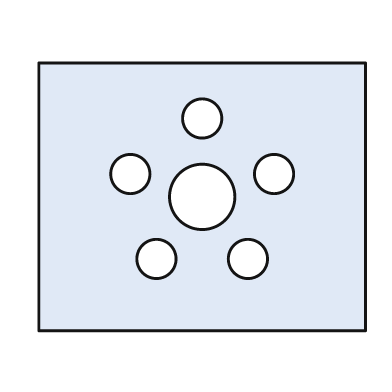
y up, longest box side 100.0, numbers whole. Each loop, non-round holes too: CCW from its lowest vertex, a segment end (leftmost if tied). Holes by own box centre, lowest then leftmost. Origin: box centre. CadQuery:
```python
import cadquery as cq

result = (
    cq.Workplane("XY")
    .moveTo(-50.0, -41.0)
    .lineTo(50.0, -41.0)
    .lineTo(50.0, 41.0)
    .lineTo(-50.0, 41.0)
    .close()
    .moveTo(-14.0, -19.0)
    .circle(6.0)
    .moveTo(14.0, -19.0)
    .circle(6.0)
    .moveTo(0.0, 0.0)
    .circle(10.0)
    .moveTo(-22.0, 7.0)
    .circle(6.0)
    .moveTo(22.0, 7.0)
    .circle(6.0)
    .moveTo(0.0, 24.0)
    .circle(6.0)
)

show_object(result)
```